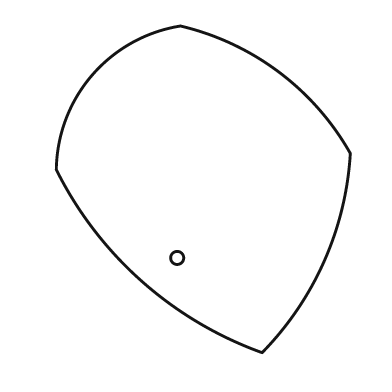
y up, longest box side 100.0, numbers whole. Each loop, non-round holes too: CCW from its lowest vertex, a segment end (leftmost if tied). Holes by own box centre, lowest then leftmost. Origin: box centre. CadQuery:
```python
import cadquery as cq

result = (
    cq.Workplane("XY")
    .moveTo(18.0, -50.0)
    .threePointArc((37.0, -22.0), (45.0, 11.0))
    .threePointArc((23.0, 36.0), (-7.0, 50.0))
    .threePointArc((-34.0, 35.0), (-45.0, 6.0))
    .threePointArc((-19.0, -28.0), (18.0, -50.0))
    .close()
    .moveTo(-8.0, -21.0)
    .circle(2.0)
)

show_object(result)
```